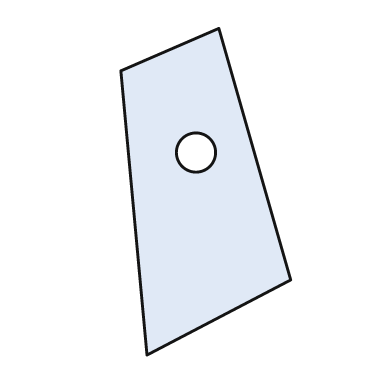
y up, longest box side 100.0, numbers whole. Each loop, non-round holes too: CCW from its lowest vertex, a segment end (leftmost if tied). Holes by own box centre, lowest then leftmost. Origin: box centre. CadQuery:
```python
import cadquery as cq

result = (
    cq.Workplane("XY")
    .moveTo(-18.0, -50.0)
    .lineTo(26.0, -27.0)
    .lineTo(4.0, 50.0)
    .lineTo(-26.0, 37.0)
    .close()
    .moveTo(-3.0, 12.0)
    .circle(6.0)
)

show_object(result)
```